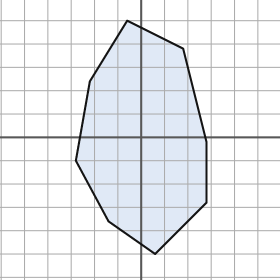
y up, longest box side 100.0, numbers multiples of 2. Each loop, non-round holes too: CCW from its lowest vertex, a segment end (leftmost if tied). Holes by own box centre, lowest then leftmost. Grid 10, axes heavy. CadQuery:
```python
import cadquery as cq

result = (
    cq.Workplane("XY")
    .moveTo(6.0, -50.0)
    .lineTo(28.0, -28.0)
    .lineTo(28.0, -2.0)
    .lineTo(18.0, 38.0)
    .lineTo(-6.0, 50.0)
    .lineTo(-22.0, 24.0)
    .lineTo(-28.0, -10.0)
    .lineTo(-14.0, -36.0)
    .close()
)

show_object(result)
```